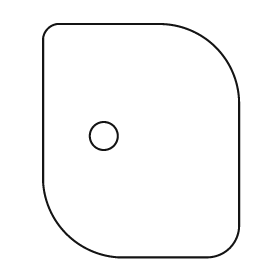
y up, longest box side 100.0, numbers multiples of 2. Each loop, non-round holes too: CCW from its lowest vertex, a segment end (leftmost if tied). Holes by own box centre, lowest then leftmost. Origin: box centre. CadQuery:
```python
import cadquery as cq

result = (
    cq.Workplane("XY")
    .moveTo(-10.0, -50.0)
    .lineTo(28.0, -50.0)
    .threePointArc((38.0, -46.0), (42.0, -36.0))
    .lineTo(42.0, 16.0)
    .threePointArc((32.0, 40.0), (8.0, 50.0))
    .lineTo(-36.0, 50.0)
    .threePointArc((-40.0, 48.0), (-42.0, 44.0))
    .lineTo(-42.0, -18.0)
    .threePointArc((-32.0, -40.0), (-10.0, -50.0))
    .close()
    .moveTo(-16.0, 2.0)
    .circle(6.0)
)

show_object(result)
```